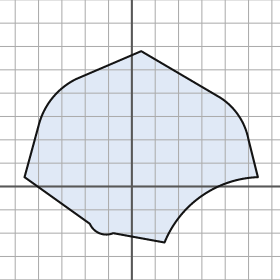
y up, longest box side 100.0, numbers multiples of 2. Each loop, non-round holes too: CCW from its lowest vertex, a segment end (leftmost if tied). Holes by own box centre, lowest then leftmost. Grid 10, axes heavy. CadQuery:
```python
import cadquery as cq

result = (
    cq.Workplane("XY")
    .moveTo(14.0, -24.0)
    .threePointArc((30.0, -4.0), (54.0, 4.0))
    .lineTo(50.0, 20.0)
    .threePointArc((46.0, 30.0), (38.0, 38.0))
    .lineTo(4.0, 58.0)
    .lineTo(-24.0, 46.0)
    .threePointArc((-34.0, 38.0), (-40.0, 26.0))
    .lineTo(-46.0, 4.0)
    .lineTo(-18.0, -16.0)
    .threePointArc((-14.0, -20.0), (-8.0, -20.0))
    .close()
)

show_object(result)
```